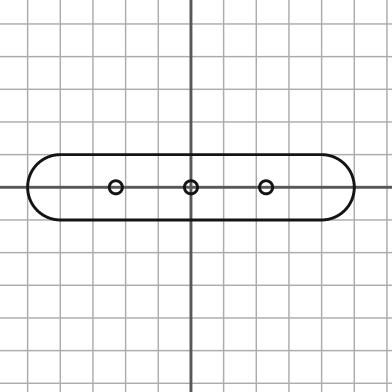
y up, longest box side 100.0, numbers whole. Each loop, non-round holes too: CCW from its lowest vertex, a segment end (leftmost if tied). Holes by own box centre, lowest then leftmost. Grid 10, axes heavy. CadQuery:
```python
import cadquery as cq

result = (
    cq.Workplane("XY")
    .moveTo(-40.0, -10.0)
    .lineTo(40.0, -10.0)
    .threePointArc((50.0, 0.0), (40.0, 10.0))
    .lineTo(-40.0, 10.0)
    .threePointArc((-50.0, 0.0), (-40.0, -10.0))
    .close()
    .moveTo(-23.0, 0.0)
    .circle(2.0)
    .moveTo(0.0, 0.0)
    .circle(2.0)
    .moveTo(23.0, 0.0)
    .circle(2.0)
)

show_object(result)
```